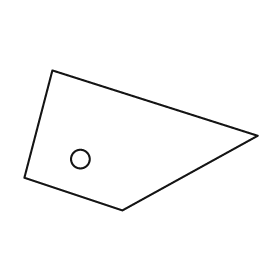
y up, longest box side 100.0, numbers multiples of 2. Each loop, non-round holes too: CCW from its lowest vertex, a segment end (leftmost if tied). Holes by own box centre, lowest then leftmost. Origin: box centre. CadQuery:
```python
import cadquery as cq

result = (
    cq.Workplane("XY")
    .moveTo(-8.0, -30.0)
    .lineTo(50.0, 2.0)
    .lineTo(-38.0, 30.0)
    .lineTo(-50.0, -16.0)
    .close()
    .moveTo(-26.0, -8.0)
    .circle(4.0)
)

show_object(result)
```